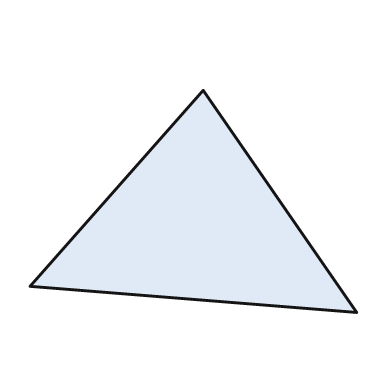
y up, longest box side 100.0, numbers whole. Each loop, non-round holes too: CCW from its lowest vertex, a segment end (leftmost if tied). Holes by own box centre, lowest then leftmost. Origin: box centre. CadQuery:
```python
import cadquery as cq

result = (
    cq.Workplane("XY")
    .moveTo(50.0, -34.0)
    .lineTo(3.0, 34.0)
    .lineTo(-50.0, -26.0)
    .close()
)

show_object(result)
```